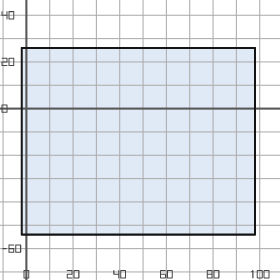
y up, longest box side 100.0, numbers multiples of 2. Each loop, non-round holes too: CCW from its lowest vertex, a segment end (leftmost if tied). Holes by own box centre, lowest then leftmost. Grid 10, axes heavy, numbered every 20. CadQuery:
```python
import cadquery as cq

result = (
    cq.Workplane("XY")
    .moveTo(-2.0, -54.0)
    .lineTo(98.0, -54.0)
    .lineTo(98.0, 26.0)
    .lineTo(-2.0, 26.0)
    .close()
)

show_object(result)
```